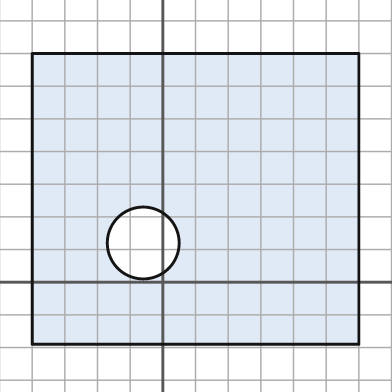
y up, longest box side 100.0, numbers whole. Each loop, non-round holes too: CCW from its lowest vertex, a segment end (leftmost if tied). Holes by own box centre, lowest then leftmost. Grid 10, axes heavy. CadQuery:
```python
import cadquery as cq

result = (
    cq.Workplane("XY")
    .moveTo(-40.0, -19.0)
    .lineTo(60.0, -19.0)
    .lineTo(60.0, 70.0)
    .lineTo(-40.0, 70.0)
    .close()
    .moveTo(-6.0, 12.0)
    .circle(11.0)
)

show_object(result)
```